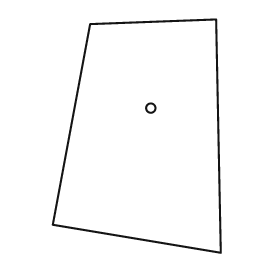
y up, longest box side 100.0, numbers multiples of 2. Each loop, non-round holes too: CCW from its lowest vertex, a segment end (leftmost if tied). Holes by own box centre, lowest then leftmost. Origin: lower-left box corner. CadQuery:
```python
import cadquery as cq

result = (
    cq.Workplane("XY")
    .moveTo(72.0, 0.0)
    .lineTo(70.0, 100.0)
    .lineTo(16.0, 98.0)
    .lineTo(0.0, 12.0)
    .close()
    .moveTo(42.0, 62.0)
    .circle(2.0)
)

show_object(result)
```